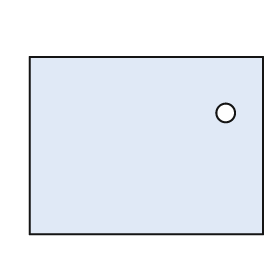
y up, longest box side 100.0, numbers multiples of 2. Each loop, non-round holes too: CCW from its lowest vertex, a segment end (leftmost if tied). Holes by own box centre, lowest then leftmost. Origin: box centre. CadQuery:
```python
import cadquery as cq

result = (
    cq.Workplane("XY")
    .moveTo(-50.0, -38.0)
    .lineTo(50.0, -38.0)
    .lineTo(50.0, 38.0)
    .lineTo(-50.0, 38.0)
    .close()
    .moveTo(34.0, 14.0)
    .circle(4.0)
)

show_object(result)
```